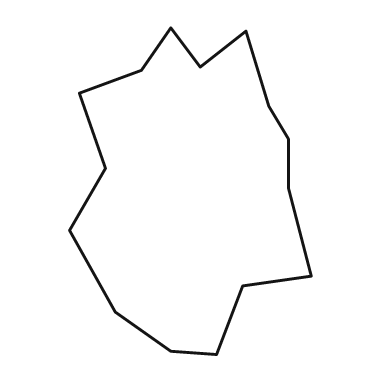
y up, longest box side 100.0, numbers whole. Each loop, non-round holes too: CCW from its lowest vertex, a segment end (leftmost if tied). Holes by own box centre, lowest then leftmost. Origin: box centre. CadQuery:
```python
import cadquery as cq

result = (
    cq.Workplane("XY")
    .moveTo(8.0, -50.0)
    .lineTo(16.0, -29.0)
    .lineTo(37.0, -26.0)
    .lineTo(30.0, 1.0)
    .lineTo(30.0, 16.0)
    .lineTo(24.0, 26.0)
    .lineTo(17.0, 49.0)
    .lineTo(3.0, 38.0)
    .lineTo(-6.0, 50.0)
    .lineTo(-15.0, 37.0)
    .lineTo(-34.0, 30.0)
    .lineTo(-26.0, 7.0)
    .lineTo(-37.0, -12.0)
    .lineTo(-23.0, -37.0)
    .lineTo(-6.0, -49.0)
    .close()
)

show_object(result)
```